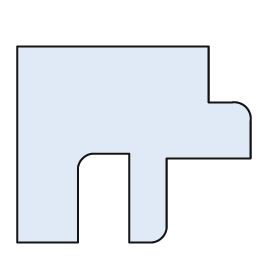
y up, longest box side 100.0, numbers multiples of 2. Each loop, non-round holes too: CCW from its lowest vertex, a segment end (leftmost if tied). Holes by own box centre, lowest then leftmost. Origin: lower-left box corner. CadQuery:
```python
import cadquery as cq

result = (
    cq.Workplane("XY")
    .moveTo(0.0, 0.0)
    .lineTo(26.0, 0.0)
    .lineTo(26.0, 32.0)
    .threePointArc((28.0, 36.0), (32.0, 38.0))
    .lineTo(48.0, 38.0)
    .lineTo(48.0, 0.0)
    .lineTo(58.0, 0.0)
    .threePointArc((62.0, 2.0), (64.0, 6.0))
    .lineTo(64.0, 36.0)
    .lineTo(100.0, 36.0)
    .lineTo(100.0, 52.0)
    .threePointArc((98.0, 58.0), (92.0, 60.0))
    .lineTo(82.0, 60.0)
    .lineTo(82.0, 84.0)
    .lineTo(0.0, 84.0)
    .close()
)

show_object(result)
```